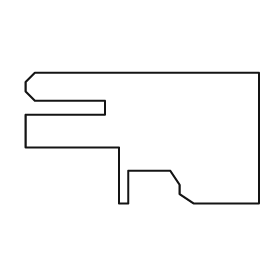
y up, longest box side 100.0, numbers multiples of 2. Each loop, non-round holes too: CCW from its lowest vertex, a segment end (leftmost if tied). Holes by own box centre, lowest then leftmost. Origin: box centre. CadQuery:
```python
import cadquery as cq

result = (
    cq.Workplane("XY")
    .moveTo(-10.0, -28.0)
    .lineTo(-6.0, -28.0)
    .lineTo(-6.0, -14.0)
    .lineTo(12.0, -14.0)
    .lineTo(16.0, -20.0)
    .lineTo(16.0, -24.0)
    .lineTo(22.0, -28.0)
    .lineTo(50.0, -28.0)
    .lineTo(50.0, 28.0)
    .lineTo(-46.0, 28.0)
    .lineTo(-50.0, 24.0)
    .lineTo(-50.0, 20.0)
    .lineTo(-46.0, 16.0)
    .lineTo(-16.0, 16.0)
    .lineTo(-16.0, 10.0)
    .lineTo(-50.0, 10.0)
    .lineTo(-50.0, -4.0)
    .lineTo(-10.0, -4.0)
    .close()
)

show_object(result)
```